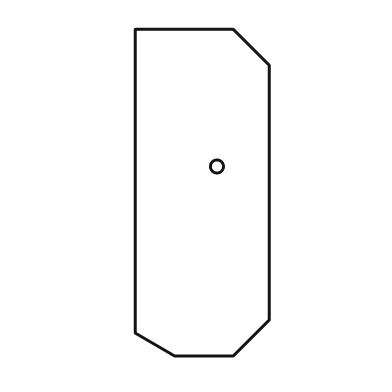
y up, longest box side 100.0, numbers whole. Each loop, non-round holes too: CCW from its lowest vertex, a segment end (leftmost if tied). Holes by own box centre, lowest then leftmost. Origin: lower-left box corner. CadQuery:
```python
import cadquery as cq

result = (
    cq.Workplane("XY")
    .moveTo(12.0, 0.0)
    .lineTo(30.0, 0.0)
    .lineTo(41.0, 11.0)
    .lineTo(41.0, 89.0)
    .lineTo(30.0, 100.0)
    .lineTo(0.0, 100.0)
    .lineTo(0.0, 7.0)
    .close()
    .moveTo(25.0, 58.0)
    .circle(2.0)
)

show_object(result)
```